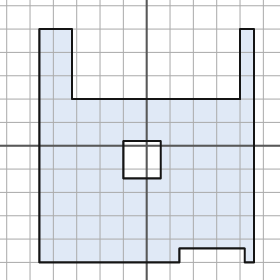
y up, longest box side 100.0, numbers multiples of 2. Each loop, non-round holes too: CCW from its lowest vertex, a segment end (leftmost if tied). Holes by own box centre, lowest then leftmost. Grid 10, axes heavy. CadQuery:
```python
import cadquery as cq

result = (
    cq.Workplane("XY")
    .moveTo(-46.0, -50.0)
    .lineTo(14.0, -50.0)
    .lineTo(14.0, -44.0)
    .lineTo(42.0, -44.0)
    .lineTo(42.0, -50.0)
    .lineTo(46.0, -50.0)
    .lineTo(46.0, 50.0)
    .lineTo(40.0, 50.0)
    .lineTo(40.0, 20.0)
    .lineTo(-32.0, 20.0)
    .lineTo(-32.0, 50.0)
    .lineTo(-46.0, 50.0)
    .close()
    .moveTo(-10.0, -14.0)
    .lineTo(6.0, -14.0)
    .lineTo(6.0, 2.0)
    .lineTo(-10.0, 2.0)
    .close()
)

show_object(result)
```